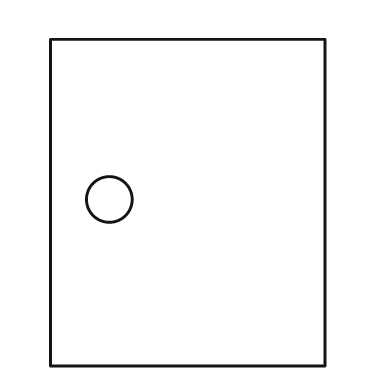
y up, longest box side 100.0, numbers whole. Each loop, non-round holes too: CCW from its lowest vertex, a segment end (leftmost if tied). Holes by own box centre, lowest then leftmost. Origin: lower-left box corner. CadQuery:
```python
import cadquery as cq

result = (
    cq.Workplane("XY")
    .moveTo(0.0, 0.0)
    .lineTo(84.0, 0.0)
    .lineTo(84.0, 100.0)
    .lineTo(0.0, 100.0)
    .close()
    .moveTo(18.0, 51.0)
    .circle(7.0)
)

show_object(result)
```